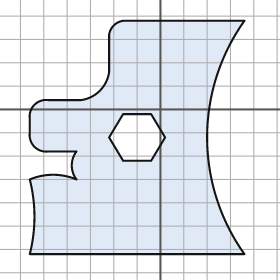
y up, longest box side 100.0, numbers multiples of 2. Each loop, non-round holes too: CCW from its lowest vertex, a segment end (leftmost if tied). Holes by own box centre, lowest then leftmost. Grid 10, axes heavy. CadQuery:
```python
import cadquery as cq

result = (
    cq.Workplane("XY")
    .moveTo(-56.0, -62.0)
    .lineTo(36.0, -62.0)
    .threePointArc((20.0, -12.0), (36.0, 38.0))
    .lineTo(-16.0, 38.0)
    .threePointArc((-20.0, 36.0), (-22.0, 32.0))
    .lineTo(-22.0, 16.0)
    .threePointArc((-26.0, 8.0), (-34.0, 4.0))
    .lineTo(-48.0, 4.0)
    .threePointArc((-54.0, 2.0), (-56.0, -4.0))
    .lineTo(-56.0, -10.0)
    .threePointArc((-54.0, -16.0), (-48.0, -18.0))
    .lineTo(-36.0, -18.0)
    .threePointArc((-38.0, -24.0), (-36.0, -30.0))
    .threePointArc((-46.0, -28.0), (-56.0, -30.0))
    .threePointArc((-54.0, -46.0), (-56.0, -62.0))
    .close()
    .moveTo(-16.0, -22.0)
    .lineTo(-4.0, -22.0)
    .lineTo(2.0, -12.0)
    .lineTo(-4.0, -2.0)
    .lineTo(-16.0, -2.0)
    .lineTo(-22.0, -12.0)
    .close()
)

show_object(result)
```